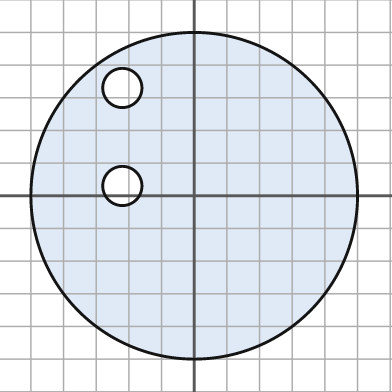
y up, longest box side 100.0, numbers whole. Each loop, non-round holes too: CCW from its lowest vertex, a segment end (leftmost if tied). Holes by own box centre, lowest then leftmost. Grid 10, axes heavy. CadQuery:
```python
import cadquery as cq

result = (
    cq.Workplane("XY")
    .moveTo(0.0, 0.0)
    .circle(50.0)
    .moveTo(-22.0, 3.0)
    .circle(6.0)
    .moveTo(-22.0, 33.0)
    .circle(6.0)
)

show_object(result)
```